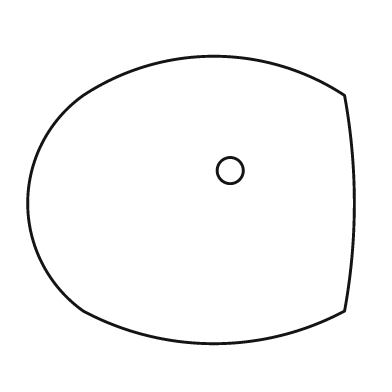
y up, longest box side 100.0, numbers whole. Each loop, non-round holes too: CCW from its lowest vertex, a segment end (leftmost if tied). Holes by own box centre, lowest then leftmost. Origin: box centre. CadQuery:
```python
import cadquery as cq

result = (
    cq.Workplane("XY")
    .moveTo(-33.0, -34.0)
    .threePointArc((7.0, -44.0), (47.0, -34.0))
    .threePointArc((50.0, -1.0), (47.0, 32.0))
    .threePointArc((7.0, 44.0), (-33.0, 32.0))
    .threePointArc((-50.0, -1.0), (-33.0, -34.0))
    .close()
    .moveTo(12.0, 9.0)
    .circle(4.0)
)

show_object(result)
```